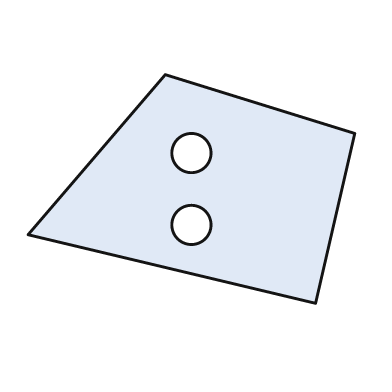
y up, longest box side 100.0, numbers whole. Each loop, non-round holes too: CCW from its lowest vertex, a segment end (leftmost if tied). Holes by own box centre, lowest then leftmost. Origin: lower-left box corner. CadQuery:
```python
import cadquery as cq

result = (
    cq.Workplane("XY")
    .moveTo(88.0, 0.0)
    .lineTo(100.0, 52.0)
    .lineTo(42.0, 70.0)
    .lineTo(0.0, 21.0)
    .close()
    .moveTo(50.0, 24.0)
    .circle(6.0)
    .moveTo(50.0, 46.0)
    .circle(6.0)
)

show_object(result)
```